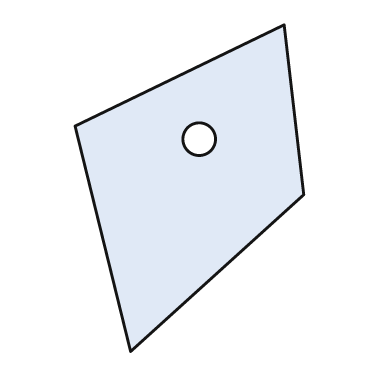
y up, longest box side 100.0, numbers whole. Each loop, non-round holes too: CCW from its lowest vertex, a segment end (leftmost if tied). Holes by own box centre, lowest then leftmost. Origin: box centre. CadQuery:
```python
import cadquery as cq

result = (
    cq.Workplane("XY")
    .moveTo(-18.0, -50.0)
    .lineTo(35.0, -2.0)
    .lineTo(29.0, 50.0)
    .lineTo(-35.0, 19.0)
    .close()
    .moveTo(3.0, 15.0)
    .circle(5.0)
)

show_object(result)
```